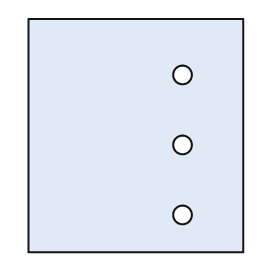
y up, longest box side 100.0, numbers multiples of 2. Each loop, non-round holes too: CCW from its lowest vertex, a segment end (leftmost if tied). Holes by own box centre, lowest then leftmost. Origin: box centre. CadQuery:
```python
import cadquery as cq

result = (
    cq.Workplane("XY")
    .moveTo(-46.0, -50.0)
    .lineTo(46.0, -50.0)
    .lineTo(46.0, 50.0)
    .lineTo(-46.0, 50.0)
    .close()
    .moveTo(20.0, -34.0)
    .circle(4.0)
    .moveTo(20.0, -4.0)
    .circle(4.0)
    .moveTo(20.0, 26.0)
    .circle(4.0)
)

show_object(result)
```